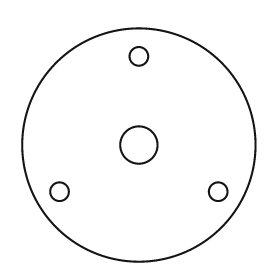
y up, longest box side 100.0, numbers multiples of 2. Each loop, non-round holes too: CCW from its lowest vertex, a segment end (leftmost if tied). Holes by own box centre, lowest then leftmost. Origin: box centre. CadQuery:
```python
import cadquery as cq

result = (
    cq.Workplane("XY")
    .moveTo(0.0, 0.0)
    .circle(50.0)
    .moveTo(-34.0, -20.0)
    .circle(4.0)
    .moveTo(34.0, -20.0)
    .circle(4.0)
    .moveTo(0.0, 0.0)
    .circle(8.0)
    .moveTo(0.0, 38.0)
    .circle(4.0)
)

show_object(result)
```